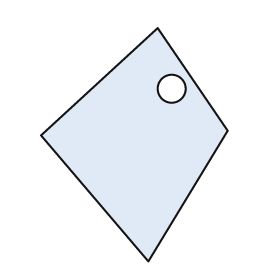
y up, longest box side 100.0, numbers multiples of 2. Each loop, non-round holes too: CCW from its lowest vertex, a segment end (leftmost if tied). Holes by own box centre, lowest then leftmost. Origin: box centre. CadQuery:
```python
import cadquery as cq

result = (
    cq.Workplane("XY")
    .moveTo(6.0, -50.0)
    .lineTo(40.0, 6.0)
    .lineTo(10.0, 50.0)
    .lineTo(-40.0, 4.0)
    .close()
    .moveTo(16.0, 24.0)
    .circle(6.0)
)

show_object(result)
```